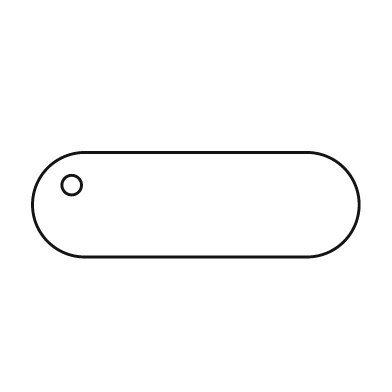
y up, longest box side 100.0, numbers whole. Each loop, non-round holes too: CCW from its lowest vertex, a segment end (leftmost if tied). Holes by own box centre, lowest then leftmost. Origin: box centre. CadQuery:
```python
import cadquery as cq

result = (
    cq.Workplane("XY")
    .moveTo(-34.0, -16.0)
    .lineTo(34.0, -16.0)
    .threePointArc((50.0, 0.0), (34.0, 16.0))
    .lineTo(-34.0, 16.0)
    .threePointArc((-50.0, 0.0), (-34.0, -16.0))
    .close()
    .moveTo(-38.0, 6.0)
    .circle(3.0)
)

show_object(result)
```